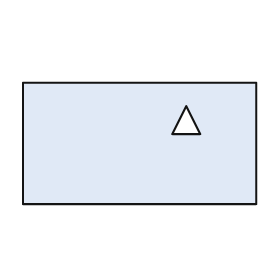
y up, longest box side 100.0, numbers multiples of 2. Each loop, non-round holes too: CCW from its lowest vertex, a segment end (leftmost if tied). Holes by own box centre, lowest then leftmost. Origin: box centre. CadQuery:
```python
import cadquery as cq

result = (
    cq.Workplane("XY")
    .moveTo(-50.0, -26.0)
    .lineTo(50.0, -26.0)
    .lineTo(50.0, 26.0)
    .lineTo(-50.0, 26.0)
    .close()
    .moveTo(14.0, 4.0)
    .lineTo(26.0, 4.0)
    .lineTo(20.0, 16.0)
    .close()
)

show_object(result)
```